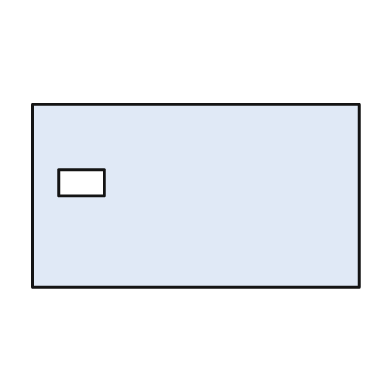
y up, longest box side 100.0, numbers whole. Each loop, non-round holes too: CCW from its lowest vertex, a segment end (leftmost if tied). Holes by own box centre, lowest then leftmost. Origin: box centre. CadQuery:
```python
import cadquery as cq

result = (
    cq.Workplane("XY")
    .moveTo(-50.0, -28.0)
    .lineTo(50.0, -28.0)
    .lineTo(50.0, 28.0)
    .lineTo(-50.0, 28.0)
    .close()
    .moveTo(-42.0, 0.0)
    .lineTo(-28.0, 0.0)
    .lineTo(-28.0, 8.0)
    .lineTo(-42.0, 8.0)
    .close()
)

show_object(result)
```